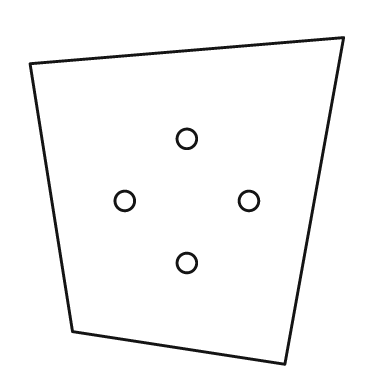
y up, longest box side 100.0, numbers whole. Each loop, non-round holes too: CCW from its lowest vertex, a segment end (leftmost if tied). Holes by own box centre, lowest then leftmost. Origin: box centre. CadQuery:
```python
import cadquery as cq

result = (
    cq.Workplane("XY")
    .moveTo(30.0, -50.0)
    .lineTo(48.0, 50.0)
    .lineTo(-48.0, 42.0)
    .lineTo(-35.0, -40.0)
    .close()
    .moveTo(0.0, -19.0)
    .circle(3.0)
    .moveTo(-19.0, 0.0)
    .circle(3.0)
    .moveTo(19.0, 0.0)
    .circle(3.0)
    .moveTo(0.0, 19.0)
    .circle(3.0)
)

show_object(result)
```